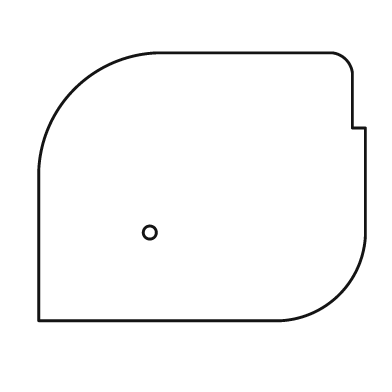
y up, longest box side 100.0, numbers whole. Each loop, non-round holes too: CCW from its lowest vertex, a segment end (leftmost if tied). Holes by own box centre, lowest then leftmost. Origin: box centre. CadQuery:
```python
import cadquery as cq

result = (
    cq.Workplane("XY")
    .moveTo(-50.0, -41.0)
    .lineTo(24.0, -41.0)
    .threePointArc((42.0, -33.0), (50.0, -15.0))
    .lineTo(50.0, 18.0)
    .lineTo(46.0, 18.0)
    .lineTo(46.0, 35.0)
    .threePointArc((44.0, 39.0), (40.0, 41.0))
    .lineTo(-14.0, 41.0)
    .threePointArc((-39.0, 30.0), (-50.0, 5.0))
    .close()
    .moveTo(-16.0, -14.0)
    .circle(2.0)
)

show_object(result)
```